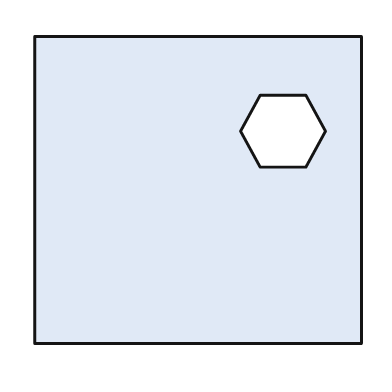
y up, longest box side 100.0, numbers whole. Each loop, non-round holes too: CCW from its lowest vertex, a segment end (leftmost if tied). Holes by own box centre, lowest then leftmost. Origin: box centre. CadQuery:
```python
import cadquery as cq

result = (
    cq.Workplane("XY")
    .moveTo(-50.0, -47.0)
    .lineTo(50.0, -47.0)
    .lineTo(50.0, 47.0)
    .lineTo(-50.0, 47.0)
    .close()
    .moveTo(19.0, 7.0)
    .lineTo(33.0, 7.0)
    .lineTo(39.0, 18.0)
    .lineTo(33.0, 29.0)
    .lineTo(19.0, 29.0)
    .lineTo(13.0, 18.0)
    .close()
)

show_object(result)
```